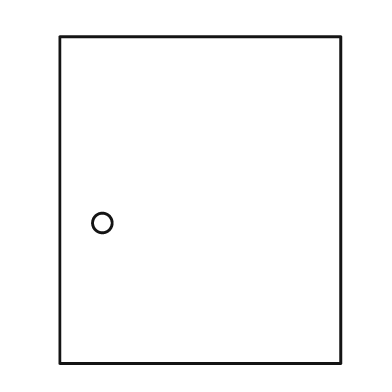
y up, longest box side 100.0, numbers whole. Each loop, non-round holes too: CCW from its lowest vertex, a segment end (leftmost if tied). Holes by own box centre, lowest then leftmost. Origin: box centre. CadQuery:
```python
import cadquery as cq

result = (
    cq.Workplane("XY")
    .moveTo(-43.0, -50.0)
    .lineTo(43.0, -50.0)
    .lineTo(43.0, 50.0)
    .lineTo(-43.0, 50.0)
    .close()
    .moveTo(-30.0, -7.0)
    .circle(3.0)
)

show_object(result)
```